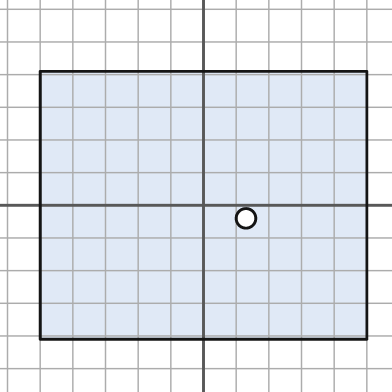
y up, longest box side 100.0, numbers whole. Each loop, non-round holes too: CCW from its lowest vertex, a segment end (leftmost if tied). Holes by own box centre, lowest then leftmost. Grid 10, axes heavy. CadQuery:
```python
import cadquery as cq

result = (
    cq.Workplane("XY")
    .moveTo(-50.0, -41.0)
    .lineTo(50.0, -41.0)
    .lineTo(50.0, 41.0)
    .lineTo(-50.0, 41.0)
    .close()
    .moveTo(13.0, -4.0)
    .circle(3.0)
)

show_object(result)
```